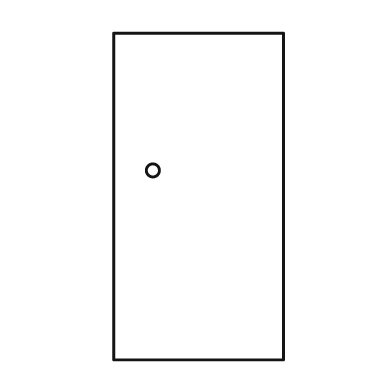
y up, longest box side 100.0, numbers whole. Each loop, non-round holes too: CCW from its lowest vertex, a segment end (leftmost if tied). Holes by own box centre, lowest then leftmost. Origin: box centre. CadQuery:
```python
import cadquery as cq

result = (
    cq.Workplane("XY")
    .moveTo(-26.0, -50.0)
    .lineTo(26.0, -50.0)
    .lineTo(26.0, 50.0)
    .lineTo(-26.0, 50.0)
    .close()
    .moveTo(-14.0, 8.0)
    .circle(2.0)
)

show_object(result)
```